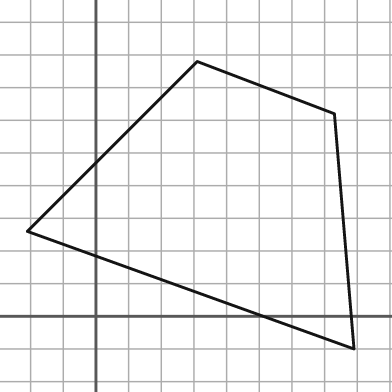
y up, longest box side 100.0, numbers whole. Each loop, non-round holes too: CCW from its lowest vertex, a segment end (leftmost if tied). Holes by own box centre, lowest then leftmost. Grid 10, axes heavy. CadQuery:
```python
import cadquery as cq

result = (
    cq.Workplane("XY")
    .moveTo(79.0, -10.0)
    .lineTo(73.0, 62.0)
    .lineTo(31.0, 78.0)
    .lineTo(-21.0, 26.0)
    .close()
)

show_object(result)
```